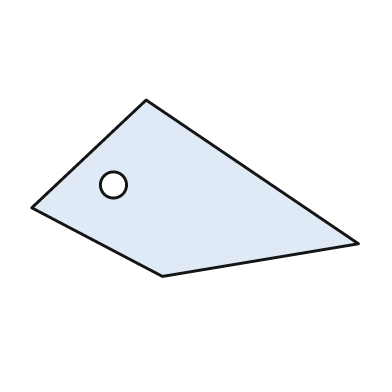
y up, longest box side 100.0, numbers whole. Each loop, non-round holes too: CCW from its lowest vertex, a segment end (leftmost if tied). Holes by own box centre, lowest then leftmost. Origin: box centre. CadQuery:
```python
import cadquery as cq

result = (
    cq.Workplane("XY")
    .moveTo(-10.0, -27.0)
    .lineTo(50.0, -17.0)
    .lineTo(-15.0, 27.0)
    .lineTo(-50.0, -6.0)
    .close()
    .moveTo(-25.0, 1.0)
    .circle(4.0)
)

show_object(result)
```